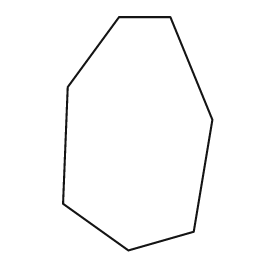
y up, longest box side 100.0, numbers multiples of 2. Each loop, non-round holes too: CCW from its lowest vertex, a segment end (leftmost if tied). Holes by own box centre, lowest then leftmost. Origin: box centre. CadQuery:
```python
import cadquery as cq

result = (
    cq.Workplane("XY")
    .moveTo(-4.0, -50.0)
    .lineTo(24.0, -42.0)
    .lineTo(32.0, 6.0)
    .lineTo(14.0, 50.0)
    .lineTo(-8.0, 50.0)
    .lineTo(-30.0, 20.0)
    .lineTo(-32.0, -30.0)
    .close()
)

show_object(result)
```